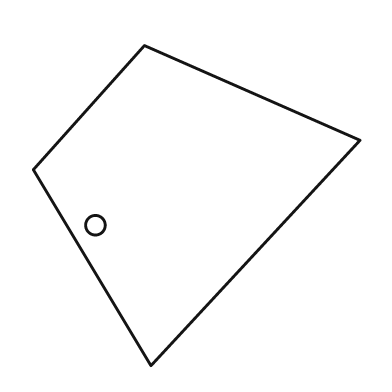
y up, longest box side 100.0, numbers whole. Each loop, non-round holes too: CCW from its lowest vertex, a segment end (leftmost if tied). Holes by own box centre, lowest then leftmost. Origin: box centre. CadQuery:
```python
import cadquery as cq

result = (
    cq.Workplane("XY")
    .moveTo(-14.0, -49.0)
    .lineTo(50.0, 20.0)
    .lineTo(-16.0, 49.0)
    .lineTo(-50.0, 11.0)
    .close()
    .moveTo(-31.0, -6.0)
    .circle(3.0)
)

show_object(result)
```